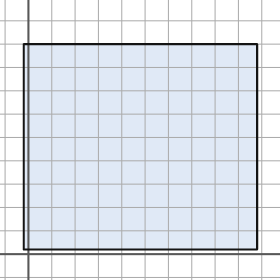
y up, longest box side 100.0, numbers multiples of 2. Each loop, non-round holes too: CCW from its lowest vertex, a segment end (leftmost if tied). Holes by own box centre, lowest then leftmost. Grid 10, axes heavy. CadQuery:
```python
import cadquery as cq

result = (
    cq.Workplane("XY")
    .moveTo(-2.0, 2.0)
    .lineTo(98.0, 2.0)
    .lineTo(98.0, 90.0)
    .lineTo(-2.0, 90.0)
    .close()
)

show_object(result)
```